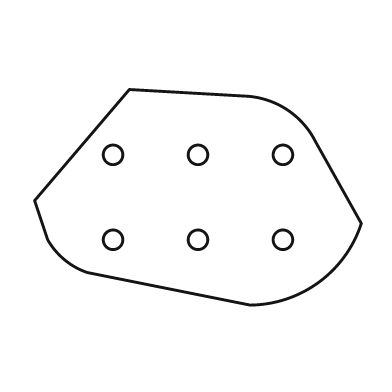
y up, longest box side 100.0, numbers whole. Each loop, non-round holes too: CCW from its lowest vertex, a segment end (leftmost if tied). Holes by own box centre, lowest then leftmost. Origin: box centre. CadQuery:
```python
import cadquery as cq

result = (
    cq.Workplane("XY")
    .moveTo(16.0, -33.0)
    .threePointArc((37.0, -26.0), (50.0, -8.0))
    .lineTo(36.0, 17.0)
    .threePointArc((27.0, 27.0), (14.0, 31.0))
    .lineTo(-21.0, 33.0)
    .lineTo(-50.0, -1.0)
    .lineTo(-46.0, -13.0)
    .threePointArc((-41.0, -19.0), (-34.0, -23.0))
    .close()
    .moveTo(-26.0, -13.0)
    .circle(3.0)
    .moveTo(0.0, -13.0)
    .circle(3.0)
    .moveTo(26.0, -13.0)
    .circle(3.0)
    .moveTo(-26.0, 13.0)
    .circle(3.0)
    .moveTo(0.0, 13.0)
    .circle(3.0)
    .moveTo(26.0, 13.0)
    .circle(3.0)
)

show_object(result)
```